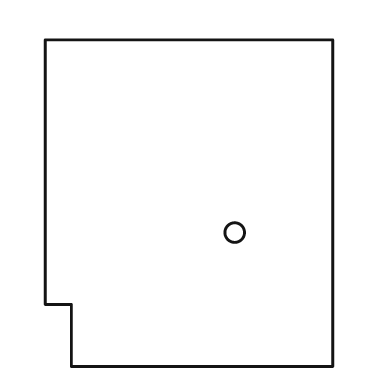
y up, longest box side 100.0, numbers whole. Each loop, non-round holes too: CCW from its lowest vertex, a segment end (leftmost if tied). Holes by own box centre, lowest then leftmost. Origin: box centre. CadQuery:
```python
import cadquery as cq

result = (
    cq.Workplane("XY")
    .moveTo(-36.0, -50.0)
    .lineTo(44.0, -50.0)
    .lineTo(44.0, 50.0)
    .lineTo(-44.0, 50.0)
    .lineTo(-44.0, -31.0)
    .lineTo(-36.0, -31.0)
    .close()
    .moveTo(14.0, -9.0)
    .circle(3.0)
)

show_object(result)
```